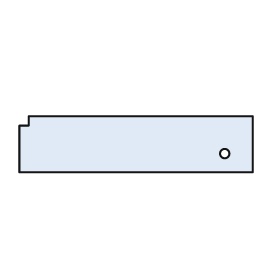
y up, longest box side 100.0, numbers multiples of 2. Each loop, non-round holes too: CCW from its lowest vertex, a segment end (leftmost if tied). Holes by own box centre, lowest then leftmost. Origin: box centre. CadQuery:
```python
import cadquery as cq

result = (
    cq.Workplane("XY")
    .moveTo(-50.0, -12.0)
    .lineTo(50.0, -12.0)
    .lineTo(50.0, 12.0)
    .lineTo(-46.0, 12.0)
    .lineTo(-46.0, 8.0)
    .lineTo(-50.0, 8.0)
    .close()
    .moveTo(38.0, -4.0)
    .circle(2.0)
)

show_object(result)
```